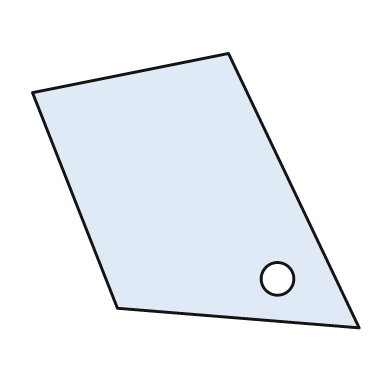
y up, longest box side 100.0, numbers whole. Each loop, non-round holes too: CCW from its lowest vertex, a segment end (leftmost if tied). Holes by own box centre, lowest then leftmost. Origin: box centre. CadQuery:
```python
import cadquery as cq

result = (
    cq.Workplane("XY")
    .moveTo(50.0, -42.0)
    .lineTo(10.0, 42.0)
    .lineTo(-50.0, 30.0)
    .lineTo(-24.0, -36.0)
    .close()
    .moveTo(25.0, -27.0)
    .circle(5.0)
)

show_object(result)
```